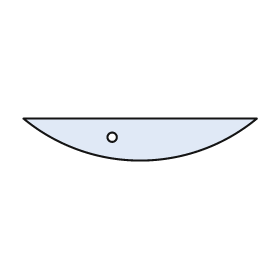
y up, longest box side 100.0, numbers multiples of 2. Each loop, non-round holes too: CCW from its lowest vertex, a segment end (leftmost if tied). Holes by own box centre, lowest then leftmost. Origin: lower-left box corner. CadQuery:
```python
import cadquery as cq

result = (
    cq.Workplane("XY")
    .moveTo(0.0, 18.0)
    .threePointArc((50.0, 0.0), (100.0, 18.0))
    .close()
    .moveTo(38.0, 10.0)
    .circle(2.0)
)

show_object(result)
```